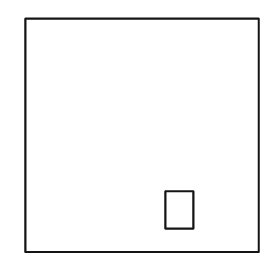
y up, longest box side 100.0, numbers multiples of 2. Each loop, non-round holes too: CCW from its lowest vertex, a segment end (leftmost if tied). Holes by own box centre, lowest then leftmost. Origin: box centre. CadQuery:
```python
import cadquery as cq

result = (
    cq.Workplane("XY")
    .moveTo(-50.0, -50.0)
    .lineTo(50.0, -50.0)
    .lineTo(50.0, 50.0)
    .lineTo(-50.0, 50.0)
    .close()
    .moveTo(10.0, -40.0)
    .lineTo(22.0, -40.0)
    .lineTo(22.0, -24.0)
    .lineTo(10.0, -24.0)
    .close()
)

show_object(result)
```